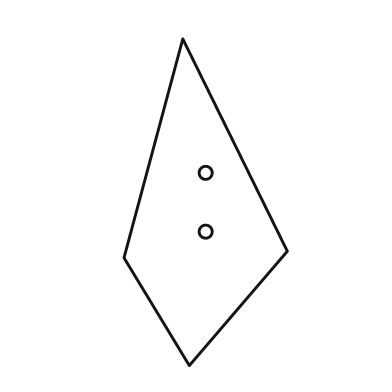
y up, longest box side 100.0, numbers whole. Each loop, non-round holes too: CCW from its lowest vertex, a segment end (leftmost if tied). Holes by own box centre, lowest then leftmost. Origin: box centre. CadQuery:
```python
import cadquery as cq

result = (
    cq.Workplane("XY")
    .moveTo(-5.0, -50.0)
    .lineTo(25.0, -15.0)
    .lineTo(-7.0, 50.0)
    .lineTo(-25.0, -17.0)
    .close()
    .moveTo(0.0, -9.0)
    .circle(2.0)
    .moveTo(0.0, 9.0)
    .circle(2.0)
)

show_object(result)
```